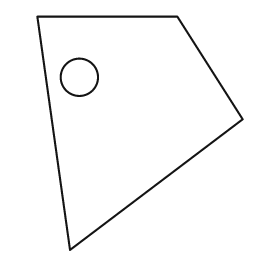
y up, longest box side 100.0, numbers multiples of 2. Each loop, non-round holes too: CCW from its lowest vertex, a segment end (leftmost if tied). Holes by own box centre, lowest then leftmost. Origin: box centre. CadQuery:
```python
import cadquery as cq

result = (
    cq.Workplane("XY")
    .moveTo(-30.0, -50.0)
    .lineTo(44.0, 6.0)
    .lineTo(16.0, 50.0)
    .lineTo(-44.0, 50.0)
    .close()
    .moveTo(-26.0, 24.0)
    .circle(8.0)
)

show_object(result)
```